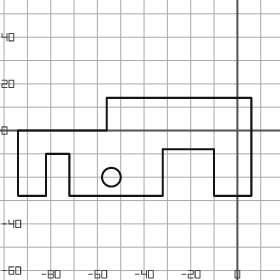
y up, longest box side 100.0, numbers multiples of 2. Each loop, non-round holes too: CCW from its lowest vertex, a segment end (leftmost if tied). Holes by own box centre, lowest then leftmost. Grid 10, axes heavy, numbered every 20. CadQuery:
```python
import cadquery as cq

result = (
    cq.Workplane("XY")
    .moveTo(-94.0, -28.0)
    .lineTo(-82.0, -28.0)
    .lineTo(-82.0, -10.0)
    .lineTo(-72.0, -10.0)
    .lineTo(-72.0, -28.0)
    .lineTo(-32.0, -28.0)
    .lineTo(-32.0, -8.0)
    .lineTo(-10.0, -8.0)
    .lineTo(-10.0, -28.0)
    .lineTo(6.0, -28.0)
    .lineTo(6.0, 14.0)
    .lineTo(-56.0, 14.0)
    .lineTo(-56.0, 0.0)
    .lineTo(-94.0, 0.0)
    .close()
    .moveTo(-54.0, -20.0)
    .circle(4.0)
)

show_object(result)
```